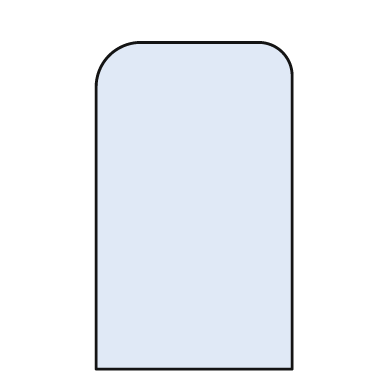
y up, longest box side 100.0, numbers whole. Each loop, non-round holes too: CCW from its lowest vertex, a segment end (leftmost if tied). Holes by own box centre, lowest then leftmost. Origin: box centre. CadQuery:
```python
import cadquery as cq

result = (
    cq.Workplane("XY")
    .moveTo(-30.0, -50.0)
    .lineTo(30.0, -50.0)
    .lineTo(30.0, 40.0)
    .threePointArc((27.0, 47.0), (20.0, 50.0))
    .lineTo(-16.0, 50.0)
    .threePointArc((-26.0, 46.0), (-30.0, 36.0))
    .close()
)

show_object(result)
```